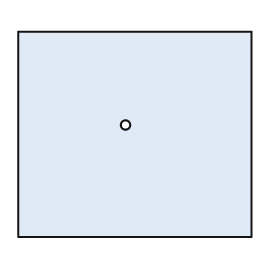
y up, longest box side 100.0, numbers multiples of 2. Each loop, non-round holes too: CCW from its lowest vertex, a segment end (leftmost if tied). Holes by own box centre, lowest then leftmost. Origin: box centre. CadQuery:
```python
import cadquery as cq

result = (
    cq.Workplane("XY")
    .moveTo(-50.0, -44.0)
    .lineTo(50.0, -44.0)
    .lineTo(50.0, 44.0)
    .lineTo(-50.0, 44.0)
    .close()
    .moveTo(-4.0, 4.0)
    .circle(2.0)
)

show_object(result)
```